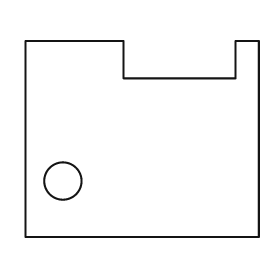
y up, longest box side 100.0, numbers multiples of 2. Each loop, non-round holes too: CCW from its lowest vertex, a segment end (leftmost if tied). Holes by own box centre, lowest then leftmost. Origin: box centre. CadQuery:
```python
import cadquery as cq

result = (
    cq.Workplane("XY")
    .moveTo(-50.0, -42.0)
    .lineTo(50.0, -42.0)
    .lineTo(50.0, 42.0)
    .lineTo(40.0, 42.0)
    .lineTo(40.0, 26.0)
    .lineTo(-8.0, 26.0)
    .lineTo(-8.0, 42.0)
    .lineTo(-50.0, 42.0)
    .close()
    .moveTo(-34.0, -18.0)
    .circle(8.0)
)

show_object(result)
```